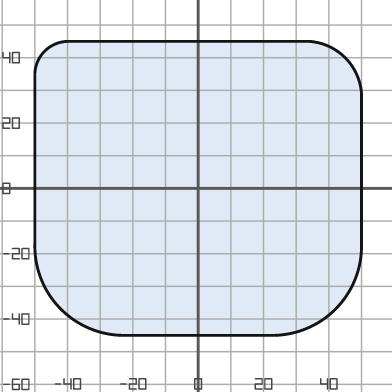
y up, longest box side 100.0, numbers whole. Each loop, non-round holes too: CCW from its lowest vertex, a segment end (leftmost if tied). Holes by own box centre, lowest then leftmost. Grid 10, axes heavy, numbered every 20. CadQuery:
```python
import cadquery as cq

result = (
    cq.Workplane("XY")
    .moveTo(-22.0, -45.0)
    .lineTo(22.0, -45.0)
    .threePointArc((42.0, -37.0), (50.0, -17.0))
    .lineTo(50.0, 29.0)
    .threePointArc((45.0, 40.0), (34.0, 45.0))
    .lineTo(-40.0, 45.0)
    .threePointArc((-47.0, 42.0), (-50.0, 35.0))
    .lineTo(-50.0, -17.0)
    .threePointArc((-42.0, -37.0), (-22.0, -45.0))
    .close()
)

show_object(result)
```